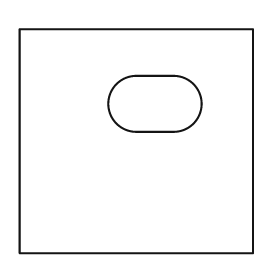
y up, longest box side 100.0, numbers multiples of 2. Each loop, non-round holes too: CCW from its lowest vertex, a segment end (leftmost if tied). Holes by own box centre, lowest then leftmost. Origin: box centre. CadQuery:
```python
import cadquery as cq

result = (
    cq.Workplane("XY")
    .moveTo(-50.0, -48.0)
    .lineTo(50.0, -48.0)
    .lineTo(50.0, 48.0)
    .lineTo(-50.0, 48.0)
    .close()
    .moveTo(0.0, 4.0)
    .lineTo(16.0, 4.0)
    .threePointArc((28.0, 16.0), (16.0, 28.0))
    .lineTo(0.0, 28.0)
    .threePointArc((-12.0, 16.0), (0.0, 4.0))
    .close()
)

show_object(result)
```